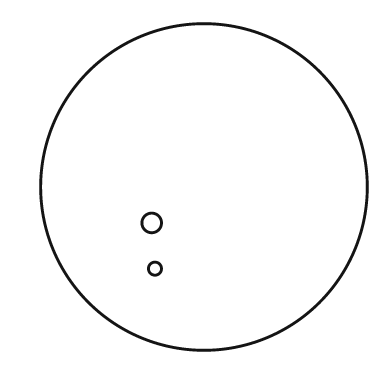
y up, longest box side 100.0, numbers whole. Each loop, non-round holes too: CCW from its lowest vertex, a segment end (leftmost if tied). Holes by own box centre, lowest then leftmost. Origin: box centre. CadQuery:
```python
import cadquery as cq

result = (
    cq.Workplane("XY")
    .moveTo(0.0, 0.0)
    .circle(50.0)
    .moveTo(-15.0, -25.0)
    .circle(2.0)
    .moveTo(-16.0, -11.0)
    .circle(3.0)
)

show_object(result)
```